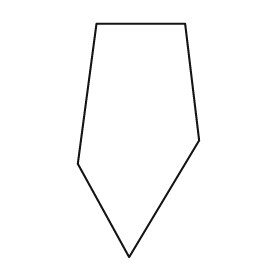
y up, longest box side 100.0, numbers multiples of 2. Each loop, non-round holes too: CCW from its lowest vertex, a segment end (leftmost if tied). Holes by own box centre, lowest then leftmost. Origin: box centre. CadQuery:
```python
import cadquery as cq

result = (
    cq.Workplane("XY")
    .moveTo(-4.0, -50.0)
    .lineTo(26.0, 0.0)
    .lineTo(20.0, 50.0)
    .lineTo(-18.0, 50.0)
    .lineTo(-26.0, -10.0)
    .close()
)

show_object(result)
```